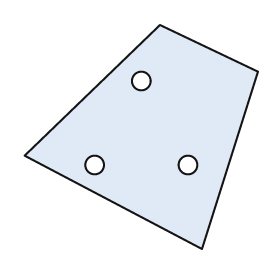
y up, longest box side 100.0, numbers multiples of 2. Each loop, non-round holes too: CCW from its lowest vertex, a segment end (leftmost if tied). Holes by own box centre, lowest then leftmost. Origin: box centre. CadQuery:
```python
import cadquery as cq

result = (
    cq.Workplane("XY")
    .moveTo(26.0, -48.0)
    .lineTo(50.0, 28.0)
    .lineTo(8.0, 48.0)
    .lineTo(-50.0, -8.0)
    .close()
    .moveTo(-20.0, -12.0)
    .circle(4.0)
    .moveTo(20.0, -12.0)
    .circle(4.0)
    .moveTo(0.0, 24.0)
    .circle(4.0)
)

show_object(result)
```